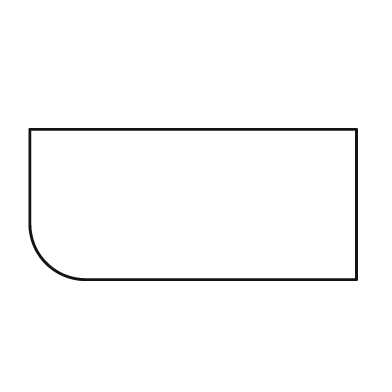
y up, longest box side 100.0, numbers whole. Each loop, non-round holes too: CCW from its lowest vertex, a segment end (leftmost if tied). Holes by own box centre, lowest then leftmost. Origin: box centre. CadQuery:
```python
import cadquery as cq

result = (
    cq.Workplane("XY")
    .moveTo(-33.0, -23.0)
    .lineTo(50.0, -23.0)
    .lineTo(50.0, 23.0)
    .lineTo(-50.0, 23.0)
    .lineTo(-50.0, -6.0)
    .threePointArc((-45.0, -18.0), (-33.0, -23.0))
    .close()
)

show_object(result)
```